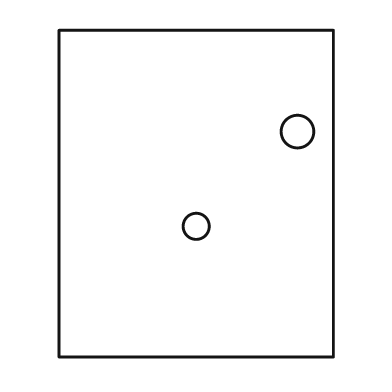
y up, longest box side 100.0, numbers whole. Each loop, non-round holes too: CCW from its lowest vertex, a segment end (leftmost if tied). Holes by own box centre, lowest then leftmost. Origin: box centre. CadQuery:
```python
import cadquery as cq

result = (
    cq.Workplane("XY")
    .moveTo(-42.0, -50.0)
    .lineTo(42.0, -50.0)
    .lineTo(42.0, 50.0)
    .lineTo(-42.0, 50.0)
    .close()
    .moveTo(0.0, -10.0)
    .circle(4.0)
    .moveTo(31.0, 19.0)
    .circle(5.0)
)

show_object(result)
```